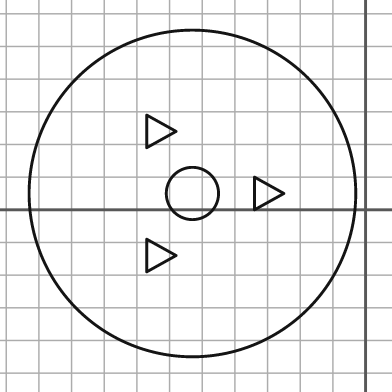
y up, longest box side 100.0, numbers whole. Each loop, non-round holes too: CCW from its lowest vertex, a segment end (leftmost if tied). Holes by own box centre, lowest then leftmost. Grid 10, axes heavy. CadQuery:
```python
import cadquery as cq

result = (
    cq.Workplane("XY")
    .moveTo(-53.0, 5.0)
    .circle(50.0)
    .moveTo(-67.0, -19.0)
    .lineTo(-58.0, -14.0)
    .lineTo(-67.0, -9.0)
    .close()
    .moveTo(-53.0, 5.0)
    .circle(8.0)
    .moveTo(-34.0, 0.0)
    .lineTo(-25.0, 5.0)
    .lineTo(-34.0, 10.0)
    .close()
    .moveTo(-67.0, 19.0)
    .lineTo(-58.0, 24.0)
    .lineTo(-67.0, 29.0)
    .close()
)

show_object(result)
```